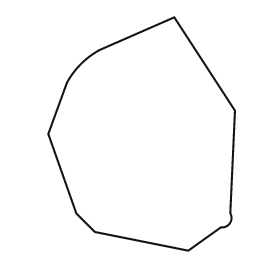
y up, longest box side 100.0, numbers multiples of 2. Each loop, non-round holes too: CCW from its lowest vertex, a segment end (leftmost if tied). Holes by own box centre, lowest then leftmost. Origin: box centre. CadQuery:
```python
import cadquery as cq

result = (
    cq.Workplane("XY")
    .moveTo(20.0, -50.0)
    .lineTo(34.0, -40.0)
    .threePointArc((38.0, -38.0), (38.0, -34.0))
    .lineTo(40.0, 10.0)
    .lineTo(14.0, 50.0)
    .lineTo(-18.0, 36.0)
    .threePointArc((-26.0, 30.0), (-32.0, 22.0))
    .lineTo(-40.0, 0.0)
    .lineTo(-28.0, -34.0)
    .lineTo(-20.0, -42.0)
    .close()
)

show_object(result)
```